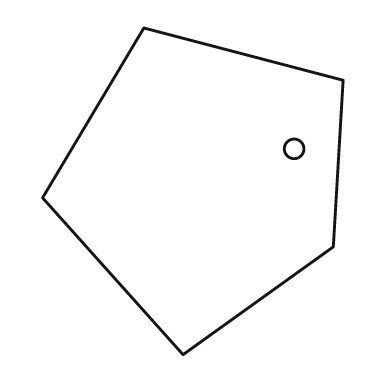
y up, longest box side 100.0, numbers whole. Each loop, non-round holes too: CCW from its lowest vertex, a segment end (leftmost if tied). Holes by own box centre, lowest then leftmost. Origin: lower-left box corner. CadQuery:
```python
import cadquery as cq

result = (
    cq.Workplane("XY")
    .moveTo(43.0, 0.0)
    .lineTo(89.0, 33.0)
    .lineTo(92.0, 84.0)
    .lineTo(31.0, 100.0)
    .lineTo(0.0, 48.0)
    .close()
    .moveTo(77.0, 63.0)
    .circle(3.0)
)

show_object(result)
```